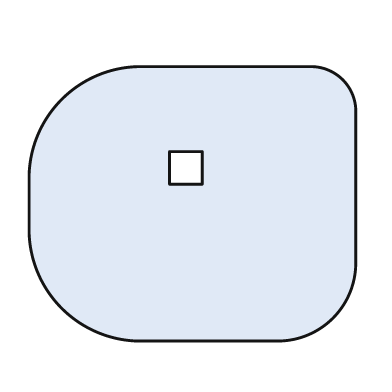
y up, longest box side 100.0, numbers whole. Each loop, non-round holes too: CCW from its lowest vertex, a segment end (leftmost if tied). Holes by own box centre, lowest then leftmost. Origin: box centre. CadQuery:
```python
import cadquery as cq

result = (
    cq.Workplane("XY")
    .moveTo(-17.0, -42.0)
    .lineTo(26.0, -42.0)
    .threePointArc((43.0, -35.0), (50.0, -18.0))
    .lineTo(50.0, 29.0)
    .threePointArc((46.0, 38.0), (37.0, 42.0))
    .lineTo(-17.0, 42.0)
    .threePointArc((-40.0, 32.0), (-50.0, 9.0))
    .lineTo(-50.0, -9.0)
    .threePointArc((-40.0, -32.0), (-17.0, -42.0))
    .close()
    .moveTo(-7.0, 6.0)
    .lineTo(3.0, 6.0)
    .lineTo(3.0, 16.0)
    .lineTo(-7.0, 16.0)
    .close()
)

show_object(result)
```